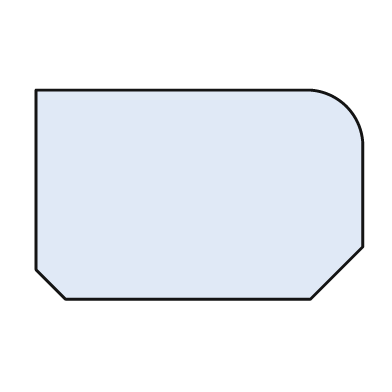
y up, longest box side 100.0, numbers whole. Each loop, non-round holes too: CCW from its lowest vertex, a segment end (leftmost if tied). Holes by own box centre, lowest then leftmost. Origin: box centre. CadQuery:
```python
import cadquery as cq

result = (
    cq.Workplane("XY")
    .moveTo(-41.0, -32.0)
    .lineTo(34.0, -32.0)
    .lineTo(50.0, -16.0)
    .lineTo(50.0, 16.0)
    .threePointArc((45.0, 27.0), (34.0, 32.0))
    .lineTo(-50.0, 32.0)
    .lineTo(-50.0, -23.0)
    .close()
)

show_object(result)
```